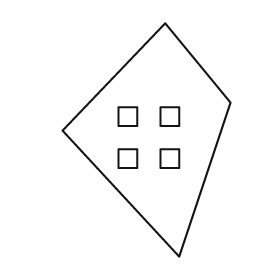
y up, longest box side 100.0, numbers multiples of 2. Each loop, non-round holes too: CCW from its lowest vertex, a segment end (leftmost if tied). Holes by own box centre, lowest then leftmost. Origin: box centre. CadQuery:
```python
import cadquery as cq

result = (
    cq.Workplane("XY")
    .moveTo(14.0, -50.0)
    .lineTo(36.0, 16.0)
    .lineTo(8.0, 50.0)
    .lineTo(-36.0, 4.0)
    .close()
    .moveTo(-12.0, -12.0)
    .lineTo(-4.0, -12.0)
    .lineTo(-4.0, -4.0)
    .lineTo(-12.0, -4.0)
    .close()
    .moveTo(6.0, -12.0)
    .lineTo(14.0, -12.0)
    .lineTo(14.0, -4.0)
    .lineTo(6.0, -4.0)
    .close()
    .moveTo(-12.0, 6.0)
    .lineTo(-4.0, 6.0)
    .lineTo(-4.0, 14.0)
    .lineTo(-12.0, 14.0)
    .close()
    .moveTo(6.0, 6.0)
    .lineTo(14.0, 6.0)
    .lineTo(14.0, 14.0)
    .lineTo(6.0, 14.0)
    .close()
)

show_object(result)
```